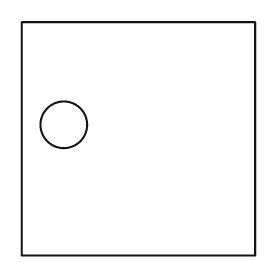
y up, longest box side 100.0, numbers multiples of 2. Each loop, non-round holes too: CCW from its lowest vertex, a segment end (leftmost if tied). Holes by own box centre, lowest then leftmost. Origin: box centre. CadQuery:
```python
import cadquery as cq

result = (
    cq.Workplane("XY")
    .moveTo(-50.0, -50.0)
    .lineTo(50.0, -50.0)
    .lineTo(50.0, 50.0)
    .lineTo(-50.0, 50.0)
    .close()
    .moveTo(-32.0, 6.0)
    .circle(10.0)
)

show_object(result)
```